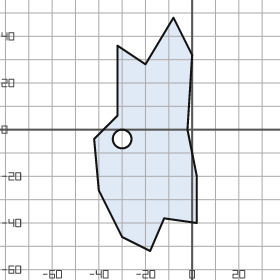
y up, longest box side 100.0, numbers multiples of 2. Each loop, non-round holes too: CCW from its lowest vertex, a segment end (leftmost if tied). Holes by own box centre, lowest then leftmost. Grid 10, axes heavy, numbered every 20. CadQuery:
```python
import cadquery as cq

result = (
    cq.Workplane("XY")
    .moveTo(-18.0, -52.0)
    .lineTo(-12.0, -38.0)
    .lineTo(2.0, -40.0)
    .lineTo(2.0, -20.0)
    .lineTo(-2.0, 0.0)
    .lineTo(0.0, 32.0)
    .lineTo(-8.0, 48.0)
    .lineTo(-20.0, 28.0)
    .lineTo(-32.0, 36.0)
    .lineTo(-32.0, 6.0)
    .lineTo(-42.0, -4.0)
    .lineTo(-40.0, -26.0)
    .lineTo(-30.0, -46.0)
    .close()
    .moveTo(-30.0, -4.0)
    .circle(4.0)
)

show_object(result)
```